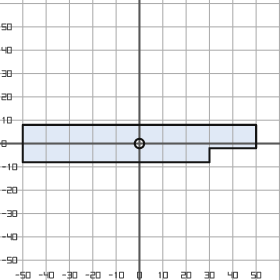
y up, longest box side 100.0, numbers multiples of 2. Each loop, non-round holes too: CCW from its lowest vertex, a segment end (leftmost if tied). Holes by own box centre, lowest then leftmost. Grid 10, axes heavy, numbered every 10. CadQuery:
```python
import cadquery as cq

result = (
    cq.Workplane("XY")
    .moveTo(-50.0, -8.0)
    .lineTo(30.0, -8.0)
    .lineTo(30.0, -2.0)
    .lineTo(50.0, -2.0)
    .lineTo(50.0, 8.0)
    .lineTo(-50.0, 8.0)
    .close()
    .moveTo(0.0, 0.0)
    .circle(2.0)
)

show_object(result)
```